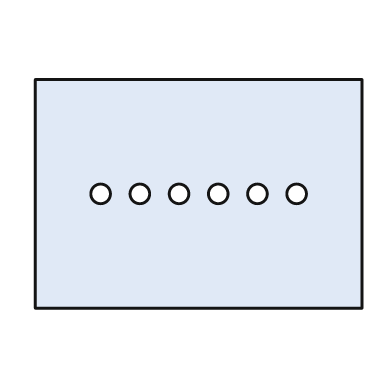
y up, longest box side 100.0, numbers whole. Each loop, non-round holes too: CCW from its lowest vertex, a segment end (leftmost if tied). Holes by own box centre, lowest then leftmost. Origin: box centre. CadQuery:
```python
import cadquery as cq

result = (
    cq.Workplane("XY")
    .moveTo(-50.0, -35.0)
    .lineTo(50.0, -35.0)
    .lineTo(50.0, 35.0)
    .lineTo(-50.0, 35.0)
    .close()
    .moveTo(-30.0, 0.0)
    .circle(3.0)
    .moveTo(-18.0, 0.0)
    .circle(3.0)
    .moveTo(-6.0, 0.0)
    .circle(3.0)
    .moveTo(6.0, 0.0)
    .circle(3.0)
    .moveTo(18.0, 0.0)
    .circle(3.0)
    .moveTo(30.0, 0.0)
    .circle(3.0)
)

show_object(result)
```